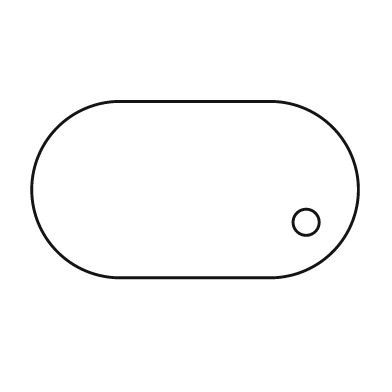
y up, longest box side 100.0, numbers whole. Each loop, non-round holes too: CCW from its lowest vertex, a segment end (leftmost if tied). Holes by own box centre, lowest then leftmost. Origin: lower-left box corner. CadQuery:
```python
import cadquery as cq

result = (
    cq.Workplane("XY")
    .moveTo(27.0, 0.0)
    .lineTo(73.0, 0.0)
    .threePointArc((100.0, 27.0), (73.0, 54.0))
    .lineTo(27.0, 54.0)
    .threePointArc((0.0, 27.0), (27.0, 0.0))
    .close()
    .moveTo(84.0, 17.0)
    .circle(4.0)
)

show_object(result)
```